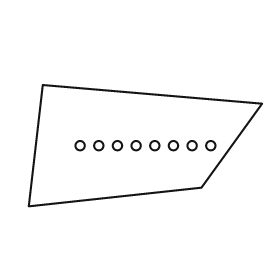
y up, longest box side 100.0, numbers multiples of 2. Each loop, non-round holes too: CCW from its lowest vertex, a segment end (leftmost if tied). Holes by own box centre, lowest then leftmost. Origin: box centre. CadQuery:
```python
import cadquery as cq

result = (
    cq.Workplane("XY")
    .moveTo(-50.0, -26.0)
    .lineTo(24.0, -18.0)
    .lineTo(50.0, 18.0)
    .lineTo(-44.0, 26.0)
    .close()
    .moveTo(-28.0, 0.0)
    .circle(2.0)
    .moveTo(-20.0, 0.0)
    .circle(2.0)
    .moveTo(-12.0, 0.0)
    .circle(2.0)
    .moveTo(-4.0, 0.0)
    .circle(2.0)
    .moveTo(4.0, 0.0)
    .circle(2.0)
    .moveTo(12.0, 0.0)
    .circle(2.0)
    .moveTo(20.0, 0.0)
    .circle(2.0)
    .moveTo(28.0, 0.0)
    .circle(2.0)
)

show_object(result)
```